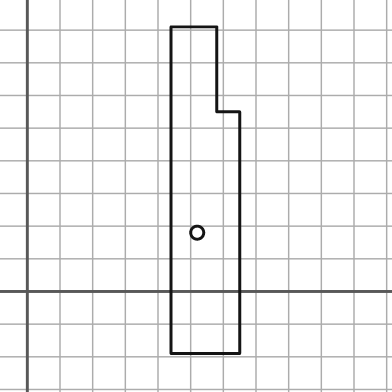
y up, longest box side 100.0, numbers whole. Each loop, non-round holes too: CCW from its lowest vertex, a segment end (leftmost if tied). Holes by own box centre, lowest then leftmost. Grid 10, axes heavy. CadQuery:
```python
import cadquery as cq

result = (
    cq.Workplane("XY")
    .moveTo(44.0, -19.0)
    .lineTo(65.0, -19.0)
    .lineTo(65.0, 55.0)
    .lineTo(58.0, 55.0)
    .lineTo(58.0, 81.0)
    .lineTo(44.0, 81.0)
    .close()
    .moveTo(52.0, 18.0)
    .circle(2.0)
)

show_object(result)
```